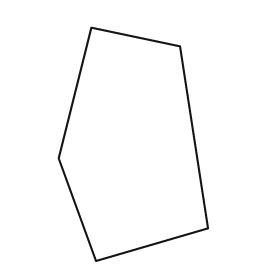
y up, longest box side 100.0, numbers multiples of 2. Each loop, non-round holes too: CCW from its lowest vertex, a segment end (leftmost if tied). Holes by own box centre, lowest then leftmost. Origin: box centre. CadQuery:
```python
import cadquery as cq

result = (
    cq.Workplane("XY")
    .moveTo(-16.0, -50.0)
    .lineTo(32.0, -36.0)
    .lineTo(20.0, 42.0)
    .lineTo(-18.0, 50.0)
    .lineTo(-32.0, -6.0)
    .close()
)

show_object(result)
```